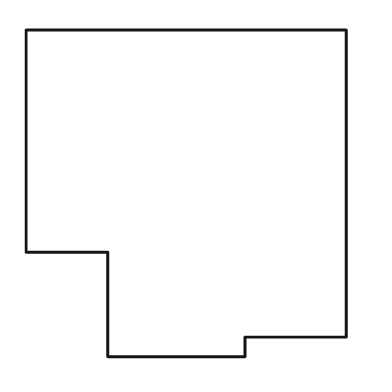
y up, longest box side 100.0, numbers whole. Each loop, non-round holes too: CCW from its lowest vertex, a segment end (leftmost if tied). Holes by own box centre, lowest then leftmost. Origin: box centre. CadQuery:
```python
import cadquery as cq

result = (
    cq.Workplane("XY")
    .moveTo(-24.0, -50.0)
    .lineTo(18.0, -50.0)
    .lineTo(18.0, -44.0)
    .lineTo(49.0, -44.0)
    .lineTo(49.0, 50.0)
    .lineTo(-49.0, 50.0)
    .lineTo(-49.0, -18.0)
    .lineTo(-24.0, -18.0)
    .close()
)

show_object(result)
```